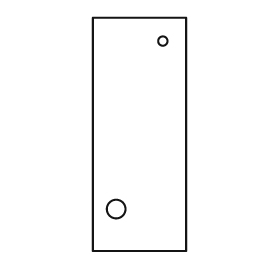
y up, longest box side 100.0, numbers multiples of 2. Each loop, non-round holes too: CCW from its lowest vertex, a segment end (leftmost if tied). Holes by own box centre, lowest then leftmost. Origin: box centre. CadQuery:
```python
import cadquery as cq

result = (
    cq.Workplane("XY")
    .moveTo(-20.0, -50.0)
    .lineTo(20.0, -50.0)
    .lineTo(20.0, 50.0)
    .lineTo(-20.0, 50.0)
    .close()
    .moveTo(-10.0, -32.0)
    .circle(4.0)
    .moveTo(10.0, 40.0)
    .circle(2.0)
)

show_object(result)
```